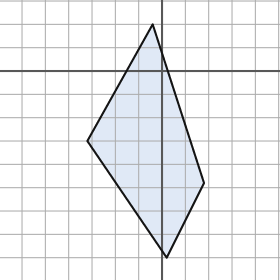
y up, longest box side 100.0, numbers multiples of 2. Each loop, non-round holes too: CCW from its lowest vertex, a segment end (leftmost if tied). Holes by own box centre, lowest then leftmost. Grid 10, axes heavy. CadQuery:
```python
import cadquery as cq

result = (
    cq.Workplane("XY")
    .moveTo(2.0, -80.0)
    .lineTo(18.0, -48.0)
    .lineTo(-4.0, 20.0)
    .lineTo(-32.0, -30.0)
    .close()
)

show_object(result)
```